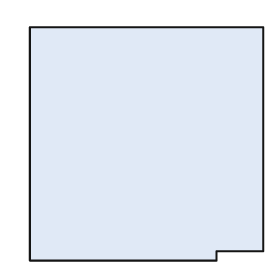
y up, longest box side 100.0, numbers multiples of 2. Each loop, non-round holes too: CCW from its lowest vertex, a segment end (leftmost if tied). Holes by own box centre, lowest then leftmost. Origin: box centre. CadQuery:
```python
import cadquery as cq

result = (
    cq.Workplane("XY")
    .moveTo(-50.0, -50.0)
    .lineTo(30.0, -50.0)
    .lineTo(30.0, -46.0)
    .lineTo(50.0, -46.0)
    .lineTo(50.0, 50.0)
    .lineTo(-50.0, 50.0)
    .close()
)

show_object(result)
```